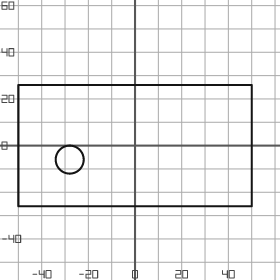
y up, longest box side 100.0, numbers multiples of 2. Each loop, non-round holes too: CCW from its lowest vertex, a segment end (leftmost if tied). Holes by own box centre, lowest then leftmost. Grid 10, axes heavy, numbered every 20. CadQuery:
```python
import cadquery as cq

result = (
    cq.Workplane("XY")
    .moveTo(-50.0, -26.0)
    .lineTo(50.0, -26.0)
    .lineTo(50.0, 26.0)
    .lineTo(-50.0, 26.0)
    .close()
    .moveTo(-28.0, -6.0)
    .circle(6.0)
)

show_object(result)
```